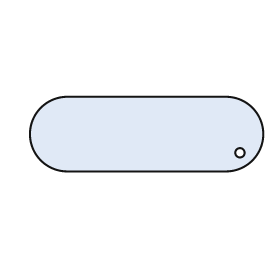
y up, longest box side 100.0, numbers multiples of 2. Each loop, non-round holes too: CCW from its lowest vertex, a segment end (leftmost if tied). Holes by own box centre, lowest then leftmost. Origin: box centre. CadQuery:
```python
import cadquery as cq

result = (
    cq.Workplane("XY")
    .moveTo(-34.0, -16.0)
    .lineTo(34.0, -16.0)
    .threePointArc((50.0, 0.0), (34.0, 16.0))
    .lineTo(-34.0, 16.0)
    .threePointArc((-50.0, 0.0), (-34.0, -16.0))
    .close()
    .moveTo(40.0, -8.0)
    .circle(2.0)
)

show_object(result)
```